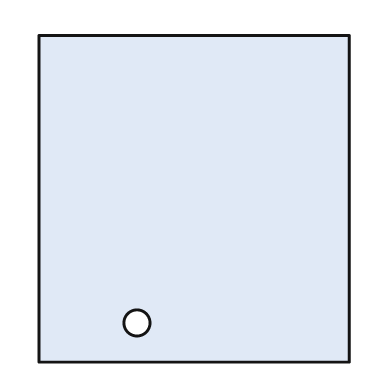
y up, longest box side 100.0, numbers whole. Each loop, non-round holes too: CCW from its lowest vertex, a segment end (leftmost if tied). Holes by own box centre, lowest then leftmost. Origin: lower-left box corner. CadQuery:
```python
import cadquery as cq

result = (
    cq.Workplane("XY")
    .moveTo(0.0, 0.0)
    .lineTo(95.0, 0.0)
    .lineTo(95.0, 100.0)
    .lineTo(0.0, 100.0)
    .close()
    .moveTo(30.0, 12.0)
    .circle(4.0)
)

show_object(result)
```